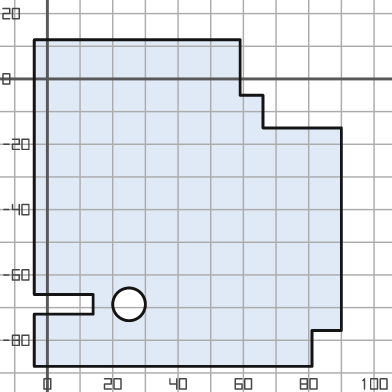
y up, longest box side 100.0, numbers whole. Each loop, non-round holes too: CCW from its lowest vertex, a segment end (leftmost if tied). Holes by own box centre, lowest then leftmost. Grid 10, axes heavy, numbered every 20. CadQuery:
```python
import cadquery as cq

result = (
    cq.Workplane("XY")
    .moveTo(-4.0, -88.0)
    .lineTo(81.0, -88.0)
    .lineTo(81.0, -77.0)
    .lineTo(90.0, -77.0)
    .lineTo(90.0, -15.0)
    .lineTo(66.0, -15.0)
    .lineTo(66.0, -5.0)
    .lineTo(59.0, -5.0)
    .lineTo(59.0, 12.0)
    .lineTo(-4.0, 12.0)
    .lineTo(-4.0, -66.0)
    .lineTo(14.0, -66.0)
    .lineTo(14.0, -72.0)
    .lineTo(-4.0, -72.0)
    .close()
    .moveTo(25.0, -69.0)
    .circle(5.0)
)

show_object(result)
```